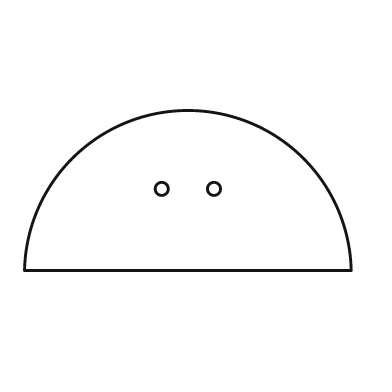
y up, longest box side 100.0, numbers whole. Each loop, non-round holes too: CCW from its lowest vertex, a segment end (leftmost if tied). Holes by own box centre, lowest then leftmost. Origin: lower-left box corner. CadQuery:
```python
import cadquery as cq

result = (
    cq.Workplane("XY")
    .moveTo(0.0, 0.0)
    .lineTo(100.0, 0.0)
    .threePointArc((50.0, 49.0), (0.0, 0.0))
    .close()
    .moveTo(42.0, 25.0)
    .circle(2.0)
    .moveTo(58.0, 25.0)
    .circle(2.0)
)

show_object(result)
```